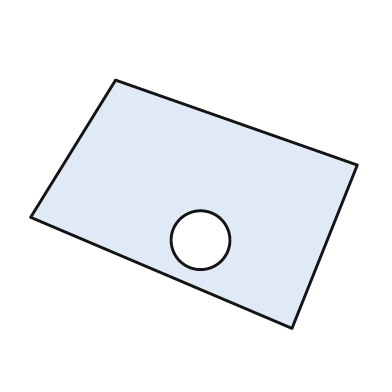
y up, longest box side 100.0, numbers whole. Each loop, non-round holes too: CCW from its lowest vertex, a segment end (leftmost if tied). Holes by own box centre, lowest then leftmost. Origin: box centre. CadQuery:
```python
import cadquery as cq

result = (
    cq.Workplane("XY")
    .moveTo(30.0, -38.0)
    .lineTo(50.0, 12.0)
    .lineTo(-24.0, 38.0)
    .lineTo(-50.0, -4.0)
    .close()
    .moveTo(2.0, -11.0)
    .circle(9.0)
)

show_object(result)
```